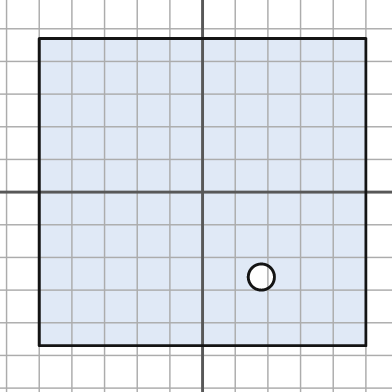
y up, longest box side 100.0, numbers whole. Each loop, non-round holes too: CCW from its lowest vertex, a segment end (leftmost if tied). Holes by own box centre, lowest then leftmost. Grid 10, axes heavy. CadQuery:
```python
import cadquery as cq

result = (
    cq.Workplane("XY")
    .moveTo(-50.0, -47.0)
    .lineTo(50.0, -47.0)
    .lineTo(50.0, 47.0)
    .lineTo(-50.0, 47.0)
    .close()
    .moveTo(18.0, -26.0)
    .circle(4.0)
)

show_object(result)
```